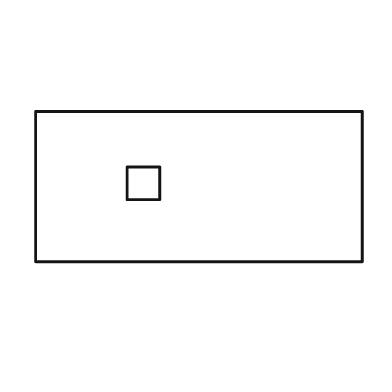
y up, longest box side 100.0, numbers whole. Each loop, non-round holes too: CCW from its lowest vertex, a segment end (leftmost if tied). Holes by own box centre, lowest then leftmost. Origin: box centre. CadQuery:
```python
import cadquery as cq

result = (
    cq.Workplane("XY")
    .moveTo(-50.0, -23.0)
    .lineTo(50.0, -23.0)
    .lineTo(50.0, 23.0)
    .lineTo(-50.0, 23.0)
    .close()
    .moveTo(-22.0, -4.0)
    .lineTo(-12.0, -4.0)
    .lineTo(-12.0, 6.0)
    .lineTo(-22.0, 6.0)
    .close()
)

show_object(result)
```